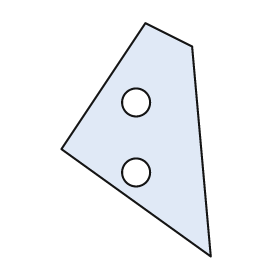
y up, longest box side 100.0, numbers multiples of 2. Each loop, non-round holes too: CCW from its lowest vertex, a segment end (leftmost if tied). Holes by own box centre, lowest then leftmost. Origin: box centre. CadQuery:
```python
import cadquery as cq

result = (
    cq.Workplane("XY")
    .moveTo(32.0, -50.0)
    .lineTo(24.0, 40.0)
    .lineTo(4.0, 50.0)
    .lineTo(-32.0, -4.0)
    .close()
    .moveTo(0.0, -14.0)
    .circle(6.0)
    .moveTo(0.0, 16.0)
    .circle(6.0)
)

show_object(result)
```